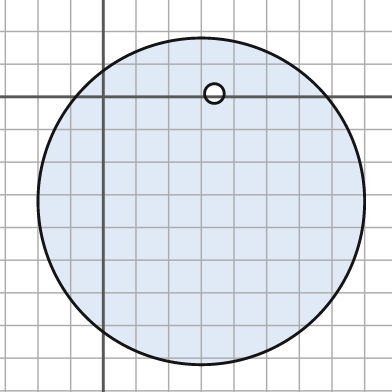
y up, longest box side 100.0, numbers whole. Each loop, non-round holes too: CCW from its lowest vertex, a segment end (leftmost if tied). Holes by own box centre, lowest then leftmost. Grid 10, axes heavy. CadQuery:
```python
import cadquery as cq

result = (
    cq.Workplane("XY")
    .moveTo(30.0, -32.0)
    .circle(50.0)
    .moveTo(34.0, 1.0)
    .circle(3.0)
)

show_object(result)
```